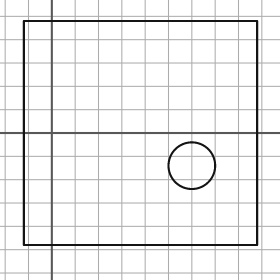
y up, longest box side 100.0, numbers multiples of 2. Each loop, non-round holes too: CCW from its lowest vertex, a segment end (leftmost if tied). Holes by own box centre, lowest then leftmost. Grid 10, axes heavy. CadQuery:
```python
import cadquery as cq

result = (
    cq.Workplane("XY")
    .moveTo(-12.0, -48.0)
    .lineTo(88.0, -48.0)
    .lineTo(88.0, 48.0)
    .lineTo(-12.0, 48.0)
    .close()
    .moveTo(60.0, -14.0)
    .circle(10.0)
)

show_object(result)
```